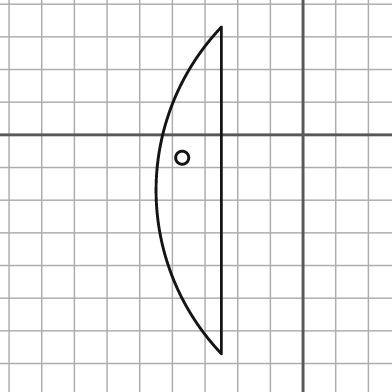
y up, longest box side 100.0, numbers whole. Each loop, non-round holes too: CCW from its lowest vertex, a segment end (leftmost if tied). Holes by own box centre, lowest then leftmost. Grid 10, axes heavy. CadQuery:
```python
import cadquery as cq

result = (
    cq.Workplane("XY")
    .moveTo(-25.0, -67.0)
    .lineTo(-25.0, 33.0)
    .threePointArc((-45.0, -17.0), (-25.0, -67.0))
    .close()
    .moveTo(-37.0, -7.0)
    .circle(2.0)
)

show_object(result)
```